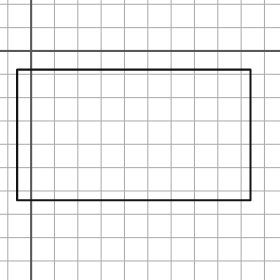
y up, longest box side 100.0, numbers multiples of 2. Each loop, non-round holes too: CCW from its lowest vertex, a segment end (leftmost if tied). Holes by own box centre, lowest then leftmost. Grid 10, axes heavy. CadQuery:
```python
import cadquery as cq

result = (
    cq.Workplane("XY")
    .moveTo(-6.0, -64.0)
    .lineTo(94.0, -64.0)
    .lineTo(94.0, -8.0)
    .lineTo(-6.0, -8.0)
    .close()
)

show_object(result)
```